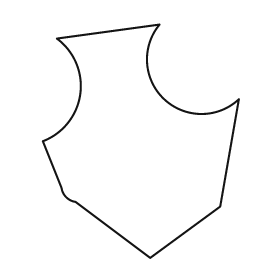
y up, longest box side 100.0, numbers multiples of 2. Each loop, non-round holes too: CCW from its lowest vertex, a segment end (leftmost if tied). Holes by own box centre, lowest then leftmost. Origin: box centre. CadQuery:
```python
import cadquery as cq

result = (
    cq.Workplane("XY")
    .moveTo(4.0, -50.0)
    .lineTo(34.0, -28.0)
    .lineTo(42.0, 18.0)
    .threePointArc((10.0, 18.0), (8.0, 50.0))
    .lineTo(-36.0, 44.0)
    .threePointArc((-26.0, 20.0), (-42.0, 0.0))
    .lineTo(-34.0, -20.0)
    .threePointArc((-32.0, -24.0), (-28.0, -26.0))
    .close()
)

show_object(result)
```